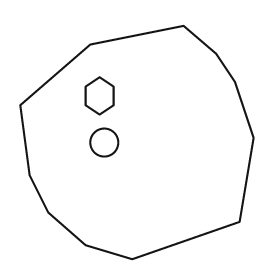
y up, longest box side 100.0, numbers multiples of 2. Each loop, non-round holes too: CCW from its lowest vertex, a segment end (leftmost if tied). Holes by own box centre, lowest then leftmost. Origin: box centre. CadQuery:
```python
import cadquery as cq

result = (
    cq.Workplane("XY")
    .moveTo(-2.0, -50.0)
    .lineTo(44.0, -34.0)
    .lineTo(50.0, 2.0)
    .lineTo(42.0, 26.0)
    .lineTo(34.0, 38.0)
    .lineTo(20.0, 50.0)
    .lineTo(-20.0, 42.0)
    .lineTo(-50.0, 16.0)
    .lineTo(-46.0, -14.0)
    .lineTo(-38.0, -30.0)
    .lineTo(-22.0, -44.0)
    .close()
    .moveTo(-14.0, 0.0)
    .circle(6.0)
    .moveTo(-16.0, 12.0)
    .lineTo(-10.0, 16.0)
    .lineTo(-10.0, 24.0)
    .lineTo(-16.0, 28.0)
    .lineTo(-22.0, 24.0)
    .lineTo(-22.0, 16.0)
    .close()
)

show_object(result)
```